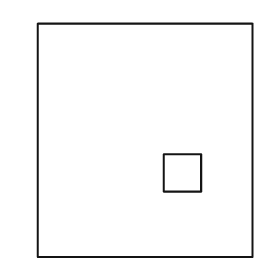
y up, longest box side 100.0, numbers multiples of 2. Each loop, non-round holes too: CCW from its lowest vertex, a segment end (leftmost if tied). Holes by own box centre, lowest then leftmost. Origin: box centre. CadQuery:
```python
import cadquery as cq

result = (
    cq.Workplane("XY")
    .moveTo(-46.0, -50.0)
    .lineTo(46.0, -50.0)
    .lineTo(46.0, 50.0)
    .lineTo(-46.0, 50.0)
    .close()
    .moveTo(8.0, -22.0)
    .lineTo(24.0, -22.0)
    .lineTo(24.0, -6.0)
    .lineTo(8.0, -6.0)
    .close()
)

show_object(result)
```